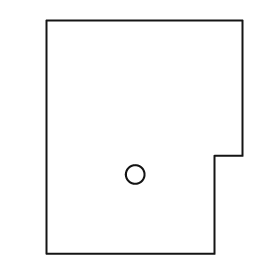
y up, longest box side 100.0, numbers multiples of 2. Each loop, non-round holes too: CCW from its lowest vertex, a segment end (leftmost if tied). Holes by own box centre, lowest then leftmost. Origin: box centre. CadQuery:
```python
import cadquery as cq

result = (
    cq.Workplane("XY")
    .moveTo(-42.0, -50.0)
    .lineTo(30.0, -50.0)
    .lineTo(30.0, -8.0)
    .lineTo(42.0, -8.0)
    .lineTo(42.0, 50.0)
    .lineTo(-42.0, 50.0)
    .close()
    .moveTo(-4.0, -16.0)
    .circle(4.0)
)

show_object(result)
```